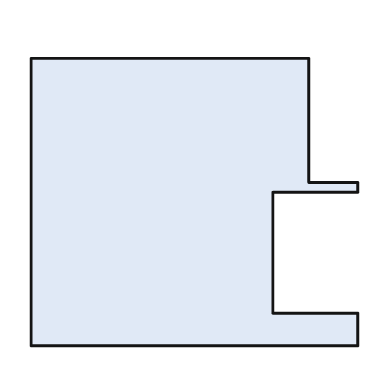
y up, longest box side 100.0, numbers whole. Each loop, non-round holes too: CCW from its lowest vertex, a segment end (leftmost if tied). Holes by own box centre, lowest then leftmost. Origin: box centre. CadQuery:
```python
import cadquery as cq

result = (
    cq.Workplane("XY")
    .moveTo(-50.0, -44.0)
    .lineTo(50.0, -44.0)
    .lineTo(50.0, -34.0)
    .lineTo(24.0, -34.0)
    .lineTo(24.0, 3.0)
    .lineTo(50.0, 3.0)
    .lineTo(50.0, 6.0)
    .lineTo(35.0, 6.0)
    .lineTo(35.0, 44.0)
    .lineTo(-50.0, 44.0)
    .close()
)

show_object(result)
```